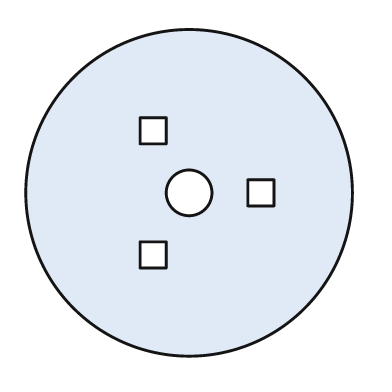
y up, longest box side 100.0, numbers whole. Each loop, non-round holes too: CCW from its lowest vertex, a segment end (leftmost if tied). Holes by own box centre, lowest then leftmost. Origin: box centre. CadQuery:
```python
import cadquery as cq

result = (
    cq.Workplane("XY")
    .moveTo(0.0, 0.0)
    .circle(50.0)
    .moveTo(-15.0, -23.0)
    .lineTo(-7.0, -23.0)
    .lineTo(-7.0, -15.0)
    .lineTo(-15.0, -15.0)
    .close()
    .moveTo(0.0, 0.0)
    .circle(7.0)
    .moveTo(18.0, -4.0)
    .lineTo(26.0, -4.0)
    .lineTo(26.0, 4.0)
    .lineTo(18.0, 4.0)
    .close()
    .moveTo(-15.0, 15.0)
    .lineTo(-7.0, 15.0)
    .lineTo(-7.0, 23.0)
    .lineTo(-15.0, 23.0)
    .close()
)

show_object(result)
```